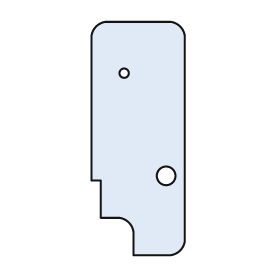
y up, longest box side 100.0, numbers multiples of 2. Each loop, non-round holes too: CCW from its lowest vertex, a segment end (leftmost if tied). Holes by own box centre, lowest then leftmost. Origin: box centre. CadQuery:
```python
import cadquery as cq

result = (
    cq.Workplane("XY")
    .moveTo(-2.0, -50.0)
    .lineTo(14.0, -50.0)
    .threePointArc((18.0, -48.0), (20.0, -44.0))
    .lineTo(20.0, 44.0)
    .threePointArc((18.0, 48.0), (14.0, 50.0))
    .lineTo(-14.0, 50.0)
    .threePointArc((-18.0, 48.0), (-20.0, 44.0))
    .lineTo(-20.0, -18.0)
    .lineTo(-16.0, -18.0)
    .lineTo(-16.0, -34.0)
    .lineTo(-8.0, -34.0)
    .threePointArc((-4.0, -36.0), (-2.0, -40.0))
    .close()
    .moveTo(12.0, -16.0)
    .circle(4.0)
    .moveTo(-6.0, 28.0)
    .circle(2.0)
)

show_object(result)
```